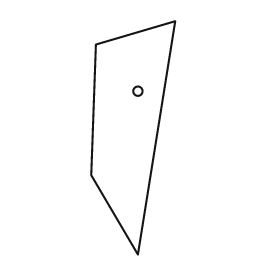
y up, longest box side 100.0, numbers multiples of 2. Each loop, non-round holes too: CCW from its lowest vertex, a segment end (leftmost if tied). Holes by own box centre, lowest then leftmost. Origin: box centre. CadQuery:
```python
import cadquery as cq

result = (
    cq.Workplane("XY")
    .moveTo(2.0, -50.0)
    .lineTo(18.0, 50.0)
    .lineTo(-16.0, 40.0)
    .lineTo(-18.0, -16.0)
    .close()
    .moveTo(2.0, 20.0)
    .circle(2.0)
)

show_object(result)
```